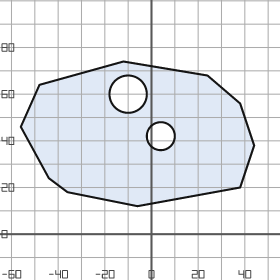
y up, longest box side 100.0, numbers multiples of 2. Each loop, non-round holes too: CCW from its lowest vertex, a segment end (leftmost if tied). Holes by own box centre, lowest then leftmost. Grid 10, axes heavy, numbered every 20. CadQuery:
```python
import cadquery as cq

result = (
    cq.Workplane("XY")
    .moveTo(-6.0, 12.0)
    .lineTo(38.0, 20.0)
    .lineTo(44.0, 38.0)
    .lineTo(38.0, 56.0)
    .lineTo(24.0, 68.0)
    .lineTo(-12.0, 74.0)
    .lineTo(-48.0, 64.0)
    .lineTo(-56.0, 46.0)
    .lineTo(-44.0, 24.0)
    .lineTo(-36.0, 18.0)
    .close()
    .moveTo(4.0, 42.0)
    .circle(6.0)
    .moveTo(-10.0, 60.0)
    .circle(8.0)
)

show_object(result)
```